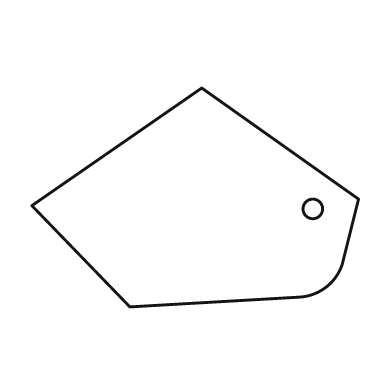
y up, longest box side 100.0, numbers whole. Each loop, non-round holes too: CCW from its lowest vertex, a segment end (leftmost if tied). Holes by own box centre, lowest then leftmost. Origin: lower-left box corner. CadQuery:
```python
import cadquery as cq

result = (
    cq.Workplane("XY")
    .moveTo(30.0, 0.0)
    .lineTo(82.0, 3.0)
    .threePointArc((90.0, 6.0), (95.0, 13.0))
    .lineTo(100.0, 33.0)
    .lineTo(52.0, 67.0)
    .lineTo(0.0, 31.0)
    .close()
    .moveTo(86.0, 30.0)
    .circle(3.0)
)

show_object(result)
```